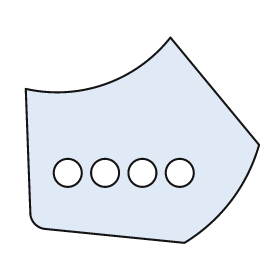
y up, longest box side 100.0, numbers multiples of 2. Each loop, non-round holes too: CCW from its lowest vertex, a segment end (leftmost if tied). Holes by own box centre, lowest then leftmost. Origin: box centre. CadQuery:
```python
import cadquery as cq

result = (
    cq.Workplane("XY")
    .moveTo(18.0, -44.0)
    .threePointArc((38.0, -26.0), (50.0, -2.0))
    .lineTo(12.0, 44.0)
    .threePointArc((-16.0, 24.0), (-50.0, 22.0))
    .lineTo(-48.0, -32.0)
    .threePointArc((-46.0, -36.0), (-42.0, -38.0))
    .close()
    .moveTo(-32.0, -14.0)
    .circle(6.0)
    .moveTo(-16.0, -14.0)
    .circle(6.0)
    .moveTo(0.0, -14.0)
    .circle(6.0)
    .moveTo(16.0, -14.0)
    .circle(6.0)
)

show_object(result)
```